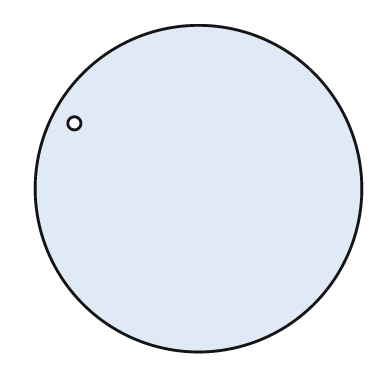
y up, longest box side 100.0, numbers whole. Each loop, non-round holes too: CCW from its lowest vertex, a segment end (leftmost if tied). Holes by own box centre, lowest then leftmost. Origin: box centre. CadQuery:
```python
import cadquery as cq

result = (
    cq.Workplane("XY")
    .moveTo(0.0, 0.0)
    .circle(50.0)
    .moveTo(-38.0, 20.0)
    .circle(2.0)
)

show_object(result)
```